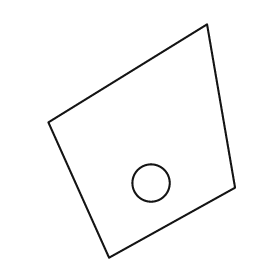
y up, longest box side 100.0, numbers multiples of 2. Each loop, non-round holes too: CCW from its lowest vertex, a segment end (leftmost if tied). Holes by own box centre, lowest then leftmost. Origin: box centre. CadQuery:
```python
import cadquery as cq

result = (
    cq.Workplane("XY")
    .moveTo(-14.0, -50.0)
    .lineTo(40.0, -20.0)
    .lineTo(28.0, 50.0)
    .lineTo(-40.0, 8.0)
    .close()
    .moveTo(4.0, -18.0)
    .circle(8.0)
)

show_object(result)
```